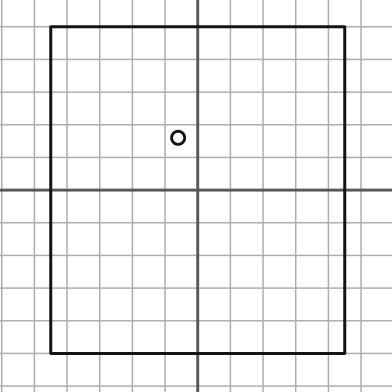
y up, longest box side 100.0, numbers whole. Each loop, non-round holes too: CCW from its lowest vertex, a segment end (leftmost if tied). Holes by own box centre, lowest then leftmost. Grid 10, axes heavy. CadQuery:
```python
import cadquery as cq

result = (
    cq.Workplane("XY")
    .moveTo(-45.0, -50.0)
    .lineTo(45.0, -50.0)
    .lineTo(45.0, 50.0)
    .lineTo(-45.0, 50.0)
    .close()
    .moveTo(-6.0, 16.0)
    .circle(2.0)
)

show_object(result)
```